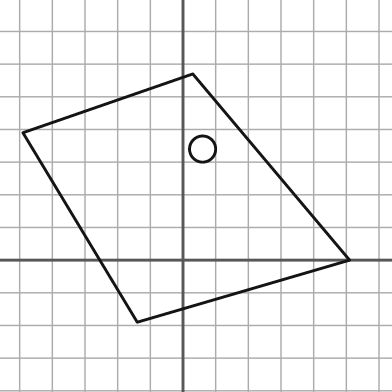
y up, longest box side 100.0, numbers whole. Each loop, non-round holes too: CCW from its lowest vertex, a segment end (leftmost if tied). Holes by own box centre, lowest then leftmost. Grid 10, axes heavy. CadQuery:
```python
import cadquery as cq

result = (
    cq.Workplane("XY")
    .moveTo(-14.0, -19.0)
    .lineTo(51.0, 0.0)
    .lineTo(3.0, 57.0)
    .lineTo(-49.0, 39.0)
    .close()
    .moveTo(6.0, 34.0)
    .circle(4.0)
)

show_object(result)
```